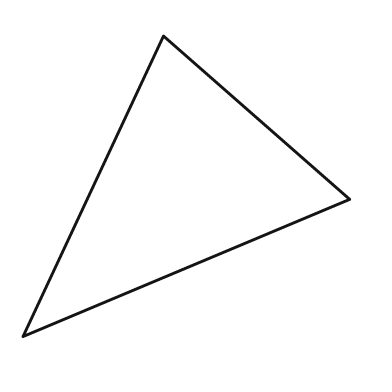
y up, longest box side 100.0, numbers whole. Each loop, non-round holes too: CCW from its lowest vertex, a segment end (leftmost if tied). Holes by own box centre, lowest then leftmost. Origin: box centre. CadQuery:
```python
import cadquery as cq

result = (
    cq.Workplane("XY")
    .moveTo(-50.0, -46.0)
    .lineTo(50.0, -4.0)
    .lineTo(-7.0, 46.0)
    .close()
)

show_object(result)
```